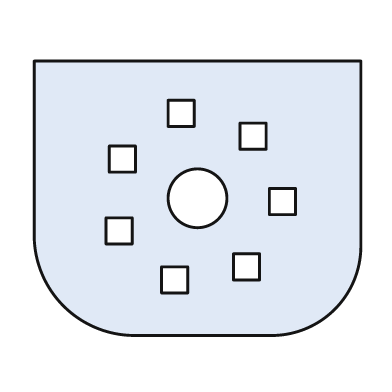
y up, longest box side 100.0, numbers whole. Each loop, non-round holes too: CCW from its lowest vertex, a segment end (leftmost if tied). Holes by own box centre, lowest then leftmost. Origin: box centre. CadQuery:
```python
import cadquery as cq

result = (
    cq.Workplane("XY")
    .moveTo(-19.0, -42.0)
    .lineTo(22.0, -42.0)
    .threePointArc((42.0, -34.0), (50.0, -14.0))
    .lineTo(50.0, 42.0)
    .lineTo(-50.0, 42.0)
    .lineTo(-50.0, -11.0)
    .threePointArc((-41.0, -33.0), (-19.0, -42.0))
    .close()
    .moveTo(-11.0, -29.0)
    .lineTo(-3.0, -29.0)
    .lineTo(-3.0, -21.0)
    .lineTo(-11.0, -21.0)
    .close()
    .moveTo(11.0, -25.0)
    .lineTo(19.0, -25.0)
    .lineTo(19.0, -17.0)
    .lineTo(11.0, -17.0)
    .close()
    .moveTo(-28.0, -14.0)
    .lineTo(-20.0, -14.0)
    .lineTo(-20.0, -6.0)
    .lineTo(-28.0, -6.0)
    .close()
    .moveTo(22.0, -5.0)
    .lineTo(30.0, -5.0)
    .lineTo(30.0, 3.0)
    .lineTo(22.0, 3.0)
    .close()
    .moveTo(0.0, 0.0)
    .circle(9.0)
    .moveTo(-27.0, 8.0)
    .lineTo(-19.0, 8.0)
    .lineTo(-19.0, 16.0)
    .lineTo(-27.0, 16.0)
    .close()
    .moveTo(13.0, 15.0)
    .lineTo(21.0, 15.0)
    .lineTo(21.0, 23.0)
    .lineTo(13.0, 23.0)
    .close()
    .moveTo(-9.0, 22.0)
    .lineTo(-1.0, 22.0)
    .lineTo(-1.0, 30.0)
    .lineTo(-9.0, 30.0)
    .close()
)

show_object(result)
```